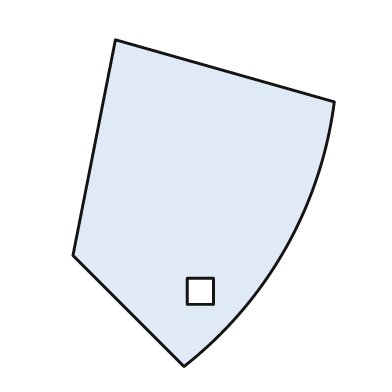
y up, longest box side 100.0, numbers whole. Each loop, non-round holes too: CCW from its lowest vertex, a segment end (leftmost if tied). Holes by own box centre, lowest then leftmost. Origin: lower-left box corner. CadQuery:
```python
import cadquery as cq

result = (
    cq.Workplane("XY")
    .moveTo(34.0, 0.0)
    .threePointArc((65.0, 36.0), (80.0, 81.0))
    .lineTo(13.0, 100.0)
    .lineTo(0.0, 34.0)
    .close()
    .moveTo(35.0, 19.0)
    .lineTo(43.0, 19.0)
    .lineTo(43.0, 27.0)
    .lineTo(35.0, 27.0)
    .close()
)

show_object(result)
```